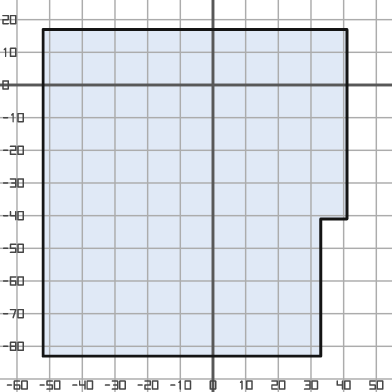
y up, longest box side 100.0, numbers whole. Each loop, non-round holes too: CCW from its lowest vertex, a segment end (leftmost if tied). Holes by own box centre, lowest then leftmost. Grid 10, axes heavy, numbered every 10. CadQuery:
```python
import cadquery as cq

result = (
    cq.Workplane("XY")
    .moveTo(-52.0, -83.0)
    .lineTo(33.0, -83.0)
    .lineTo(33.0, -41.0)
    .lineTo(41.0, -41.0)
    .lineTo(41.0, 17.0)
    .lineTo(-52.0, 17.0)
    .close()
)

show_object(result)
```